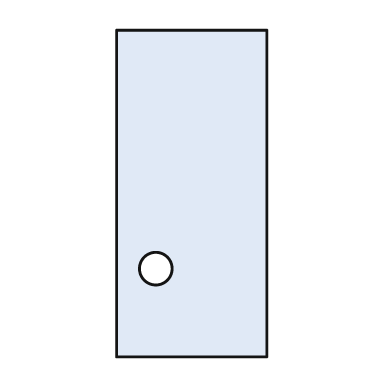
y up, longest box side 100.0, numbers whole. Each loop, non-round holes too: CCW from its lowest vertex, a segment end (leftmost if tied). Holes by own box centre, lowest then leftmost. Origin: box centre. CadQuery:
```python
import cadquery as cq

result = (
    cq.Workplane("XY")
    .moveTo(-23.0, -50.0)
    .lineTo(23.0, -50.0)
    .lineTo(23.0, 50.0)
    .lineTo(-23.0, 50.0)
    .close()
    .moveTo(-11.0, -23.0)
    .circle(5.0)
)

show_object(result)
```